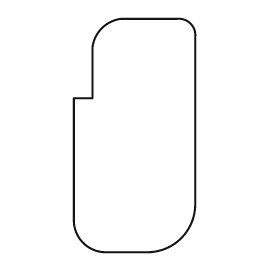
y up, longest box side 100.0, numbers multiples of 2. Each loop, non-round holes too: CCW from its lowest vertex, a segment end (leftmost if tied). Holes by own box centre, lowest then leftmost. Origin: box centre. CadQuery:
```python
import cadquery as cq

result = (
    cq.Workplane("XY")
    .moveTo(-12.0, -50.0)
    .lineTo(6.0, -50.0)
    .threePointArc((20.0, -44.0), (26.0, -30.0))
    .lineTo(26.0, 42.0)
    .threePointArc((24.0, 48.0), (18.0, 50.0))
    .lineTo(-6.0, 50.0)
    .threePointArc((-14.0, 46.0), (-18.0, 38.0))
    .lineTo(-18.0, 16.0)
    .lineTo(-26.0, 16.0)
    .lineTo(-26.0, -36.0)
    .threePointArc((-22.0, -46.0), (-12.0, -50.0))
    .close()
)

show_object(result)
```